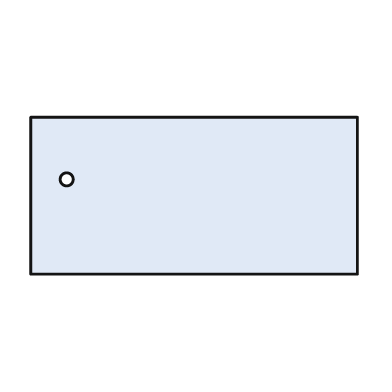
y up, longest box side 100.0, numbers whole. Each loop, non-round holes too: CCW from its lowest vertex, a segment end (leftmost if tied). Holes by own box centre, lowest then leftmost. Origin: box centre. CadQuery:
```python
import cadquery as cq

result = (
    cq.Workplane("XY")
    .moveTo(-50.0, -24.0)
    .lineTo(50.0, -24.0)
    .lineTo(50.0, 24.0)
    .lineTo(-50.0, 24.0)
    .close()
    .moveTo(-39.0, 5.0)
    .circle(2.0)
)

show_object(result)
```